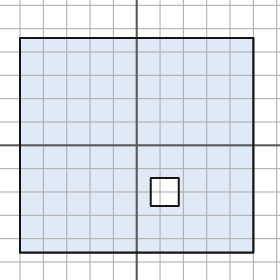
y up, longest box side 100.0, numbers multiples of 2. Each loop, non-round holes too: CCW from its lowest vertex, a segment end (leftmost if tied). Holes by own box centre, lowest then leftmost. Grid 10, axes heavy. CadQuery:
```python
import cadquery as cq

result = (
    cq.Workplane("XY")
    .moveTo(-50.0, -46.0)
    .lineTo(50.0, -46.0)
    .lineTo(50.0, 46.0)
    .lineTo(-50.0, 46.0)
    .close()
    .moveTo(6.0, -26.0)
    .lineTo(18.0, -26.0)
    .lineTo(18.0, -14.0)
    .lineTo(6.0, -14.0)
    .close()
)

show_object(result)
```